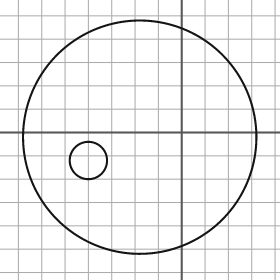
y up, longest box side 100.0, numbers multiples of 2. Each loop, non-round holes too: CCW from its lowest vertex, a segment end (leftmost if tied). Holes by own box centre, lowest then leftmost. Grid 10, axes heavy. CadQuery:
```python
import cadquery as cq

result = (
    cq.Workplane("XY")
    .moveTo(-18.0, -2.0)
    .circle(50.0)
    .moveTo(-40.0, -12.0)
    .circle(8.0)
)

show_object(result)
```